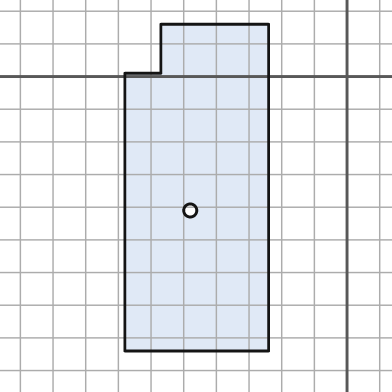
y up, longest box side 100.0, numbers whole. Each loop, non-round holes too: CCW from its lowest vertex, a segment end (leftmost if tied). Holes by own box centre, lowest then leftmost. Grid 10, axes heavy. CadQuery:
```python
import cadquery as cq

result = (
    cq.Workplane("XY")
    .moveTo(-68.0, -84.0)
    .lineTo(-24.0, -84.0)
    .lineTo(-24.0, 16.0)
    .lineTo(-57.0, 16.0)
    .lineTo(-57.0, 1.0)
    .lineTo(-68.0, 1.0)
    .close()
    .moveTo(-48.0, -41.0)
    .circle(2.0)
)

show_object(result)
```